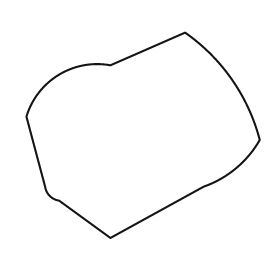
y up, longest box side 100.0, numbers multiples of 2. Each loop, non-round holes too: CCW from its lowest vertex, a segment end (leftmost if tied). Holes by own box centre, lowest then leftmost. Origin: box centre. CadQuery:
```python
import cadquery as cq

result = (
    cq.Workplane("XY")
    .moveTo(-14.0, -44.0)
    .lineTo(26.0, -22.0)
    .threePointArc((40.0, -14.0), (50.0, -2.0))
    .threePointArc((38.0, 24.0), (18.0, 44.0))
    .lineTo(-14.0, 30.0)
    .threePointArc((-36.0, 26.0), (-50.0, 8.0))
    .lineTo(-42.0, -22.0)
    .threePointArc((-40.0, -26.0), (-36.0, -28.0))
    .close()
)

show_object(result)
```